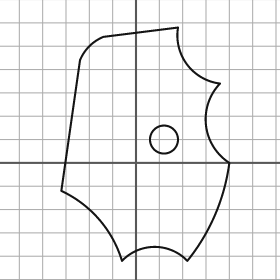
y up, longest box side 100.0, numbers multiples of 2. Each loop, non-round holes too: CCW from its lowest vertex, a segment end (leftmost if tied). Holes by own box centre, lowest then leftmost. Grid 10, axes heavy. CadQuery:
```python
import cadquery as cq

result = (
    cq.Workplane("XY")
    .moveTo(-6.0, -42.0)
    .threePointArc((8.0, -36.0), (22.0, -42.0))
    .threePointArc((34.0, -22.0), (40.0, 0.0))
    .threePointArc((30.0, 16.0), (36.0, 34.0))
    .threePointArc((22.0, 42.0), (18.0, 58.0))
    .lineTo(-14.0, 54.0)
    .threePointArc((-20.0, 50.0), (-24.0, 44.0))
    .lineTo(-32.0, -12.0)
    .threePointArc((-16.0, -24.0), (-6.0, -42.0))
    .close()
    .moveTo(12.0, 10.0)
    .circle(6.0)
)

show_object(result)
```